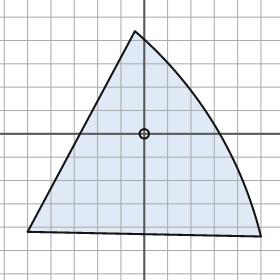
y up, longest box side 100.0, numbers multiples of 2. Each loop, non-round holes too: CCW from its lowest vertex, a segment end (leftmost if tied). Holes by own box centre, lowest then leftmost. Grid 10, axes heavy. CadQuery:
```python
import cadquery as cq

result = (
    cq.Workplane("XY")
    .moveTo(50.0, -44.0)
    .threePointArc((30.0, 4.0), (-4.0, 44.0))
    .lineTo(-50.0, -42.0)
    .close()
    .moveTo(0.0, 0.0)
    .circle(2.0)
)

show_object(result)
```